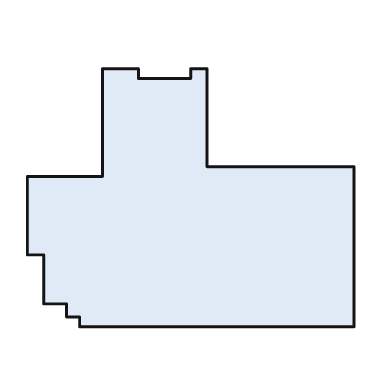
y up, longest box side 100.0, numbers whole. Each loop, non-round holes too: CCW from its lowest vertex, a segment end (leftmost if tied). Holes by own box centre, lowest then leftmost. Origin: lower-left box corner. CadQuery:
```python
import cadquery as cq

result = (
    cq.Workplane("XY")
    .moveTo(16.0, 0.0)
    .lineTo(100.0, 0.0)
    .lineTo(100.0, 49.0)
    .lineTo(55.0, 49.0)
    .lineTo(55.0, 79.0)
    .lineTo(50.0, 79.0)
    .lineTo(50.0, 76.0)
    .lineTo(34.0, 76.0)
    .lineTo(34.0, 79.0)
    .lineTo(23.0, 79.0)
    .lineTo(23.0, 46.0)
    .lineTo(0.0, 46.0)
    .lineTo(0.0, 22.0)
    .lineTo(5.0, 22.0)
    .lineTo(5.0, 7.0)
    .lineTo(12.0, 7.0)
    .lineTo(12.0, 3.0)
    .lineTo(16.0, 3.0)
    .close()
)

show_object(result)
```